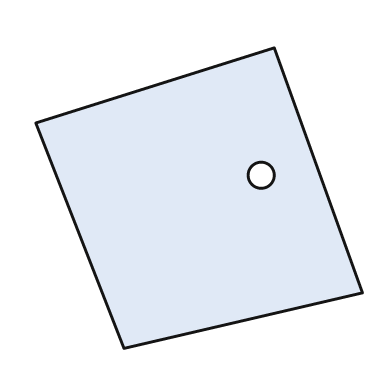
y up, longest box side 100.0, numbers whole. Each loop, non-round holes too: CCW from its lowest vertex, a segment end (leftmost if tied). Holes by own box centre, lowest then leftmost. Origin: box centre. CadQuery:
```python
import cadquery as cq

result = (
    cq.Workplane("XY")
    .moveTo(-23.0, -46.0)
    .lineTo(50.0, -29.0)
    .lineTo(23.0, 46.0)
    .lineTo(-50.0, 23.0)
    .close()
    .moveTo(19.0, 7.0)
    .circle(4.0)
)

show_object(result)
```